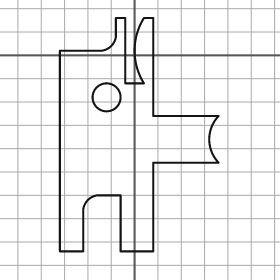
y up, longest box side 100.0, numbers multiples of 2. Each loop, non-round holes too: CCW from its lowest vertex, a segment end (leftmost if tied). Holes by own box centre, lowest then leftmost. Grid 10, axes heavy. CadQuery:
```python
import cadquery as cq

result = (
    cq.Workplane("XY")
    .moveTo(-32.0, -84.0)
    .lineTo(-22.0, -84.0)
    .lineTo(-22.0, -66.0)
    .threePointArc((-20.0, -62.0), (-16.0, -60.0))
    .lineTo(-6.0, -60.0)
    .lineTo(-6.0, -84.0)
    .lineTo(8.0, -84.0)
    .lineTo(8.0, -46.0)
    .lineTo(36.0, -46.0)
    .threePointArc((32.0, -36.0), (36.0, -26.0))
    .lineTo(8.0, -26.0)
    .lineTo(8.0, 16.0)
    .lineTo(4.0, 16.0)
    .threePointArc((0.0, 2.0), (4.0, -12.0))
    .lineTo(-4.0, -12.0)
    .lineTo(-4.0, 16.0)
    .lineTo(-8.0, 16.0)
    .lineTo(-8.0, 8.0)
    .threePointArc((-10.0, 4.0), (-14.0, 2.0))
    .lineTo(-32.0, 2.0)
    .close()
    .moveTo(-12.0, -18.0)
    .circle(6.0)
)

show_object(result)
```